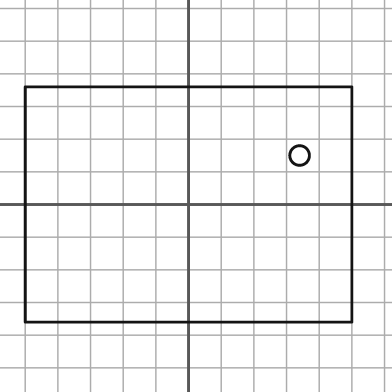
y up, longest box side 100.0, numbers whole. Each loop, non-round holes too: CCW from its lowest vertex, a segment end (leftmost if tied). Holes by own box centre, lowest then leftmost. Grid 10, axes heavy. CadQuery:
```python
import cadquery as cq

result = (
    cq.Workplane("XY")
    .moveTo(-50.0, -36.0)
    .lineTo(50.0, -36.0)
    .lineTo(50.0, 36.0)
    .lineTo(-50.0, 36.0)
    .close()
    .moveTo(34.0, 15.0)
    .circle(3.0)
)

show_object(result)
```